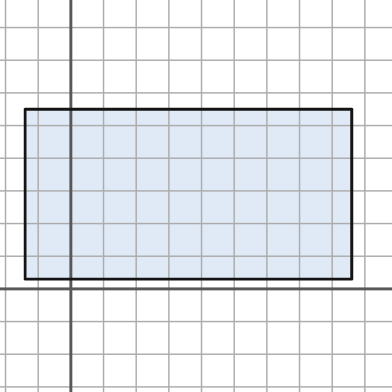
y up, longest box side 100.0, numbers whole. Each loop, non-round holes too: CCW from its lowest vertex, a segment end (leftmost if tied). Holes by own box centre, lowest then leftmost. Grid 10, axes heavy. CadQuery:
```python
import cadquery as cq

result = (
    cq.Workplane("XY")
    .moveTo(-14.0, 3.0)
    .lineTo(86.0, 3.0)
    .lineTo(86.0, 55.0)
    .lineTo(-14.0, 55.0)
    .close()
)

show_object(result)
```